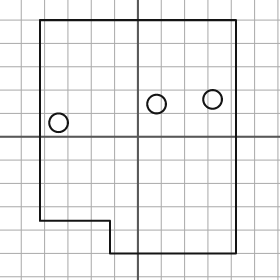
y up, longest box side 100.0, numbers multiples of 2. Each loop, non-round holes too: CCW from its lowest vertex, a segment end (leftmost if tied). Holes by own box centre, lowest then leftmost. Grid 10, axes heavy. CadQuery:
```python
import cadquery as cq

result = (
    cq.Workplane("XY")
    .moveTo(-12.0, -50.0)
    .lineTo(42.0, -50.0)
    .lineTo(42.0, 50.0)
    .lineTo(-42.0, 50.0)
    .lineTo(-42.0, -36.0)
    .lineTo(-12.0, -36.0)
    .close()
    .moveTo(-34.0, 6.0)
    .circle(4.0)
    .moveTo(8.0, 14.0)
    .circle(4.0)
    .moveTo(32.0, 16.0)
    .circle(4.0)
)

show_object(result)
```